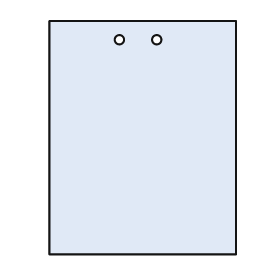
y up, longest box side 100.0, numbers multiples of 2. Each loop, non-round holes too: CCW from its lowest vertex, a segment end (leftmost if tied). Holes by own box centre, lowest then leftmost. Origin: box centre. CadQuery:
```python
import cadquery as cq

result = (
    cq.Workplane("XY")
    .moveTo(-40.0, -50.0)
    .lineTo(40.0, -50.0)
    .lineTo(40.0, 50.0)
    .lineTo(-40.0, 50.0)
    .close()
    .moveTo(-10.0, 42.0)
    .circle(2.0)
    .moveTo(6.0, 42.0)
    .circle(2.0)
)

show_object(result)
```